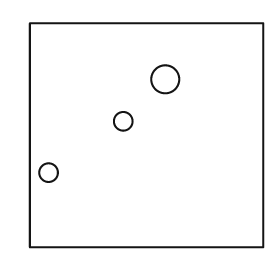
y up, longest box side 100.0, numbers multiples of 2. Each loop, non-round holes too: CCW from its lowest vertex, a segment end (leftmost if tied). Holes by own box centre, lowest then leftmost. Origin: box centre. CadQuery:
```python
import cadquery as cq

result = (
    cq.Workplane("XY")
    .moveTo(-50.0, -48.0)
    .lineTo(50.0, -48.0)
    .lineTo(50.0, 48.0)
    .lineTo(-50.0, 48.0)
    .close()
    .moveTo(-42.0, -16.0)
    .circle(4.0)
    .moveTo(-10.0, 6.0)
    .circle(4.0)
    .moveTo(8.0, 24.0)
    .circle(6.0)
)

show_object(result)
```